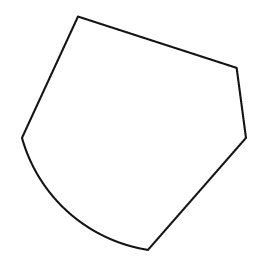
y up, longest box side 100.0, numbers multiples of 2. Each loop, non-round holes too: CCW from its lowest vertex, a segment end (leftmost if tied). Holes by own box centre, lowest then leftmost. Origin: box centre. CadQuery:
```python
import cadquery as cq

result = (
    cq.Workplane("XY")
    .moveTo(6.0, -50.0)
    .lineTo(48.0, -2.0)
    .lineTo(44.0, 28.0)
    .lineTo(-24.0, 50.0)
    .lineTo(-48.0, -2.0)
    .threePointArc((-28.0, -34.0), (6.0, -50.0))
    .close()
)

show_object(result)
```